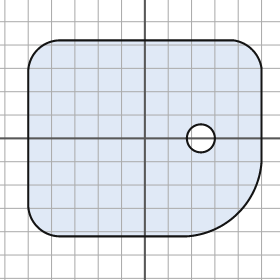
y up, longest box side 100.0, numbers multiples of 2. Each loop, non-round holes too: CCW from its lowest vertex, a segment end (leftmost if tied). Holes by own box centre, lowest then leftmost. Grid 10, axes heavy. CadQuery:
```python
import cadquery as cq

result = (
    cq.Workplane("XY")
    .moveTo(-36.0, -42.0)
    .lineTo(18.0, -42.0)
    .threePointArc((40.0, -32.0), (50.0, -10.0))
    .lineTo(50.0, 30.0)
    .threePointArc((46.0, 38.0), (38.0, 42.0))
    .lineTo(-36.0, 42.0)
    .threePointArc((-46.0, 38.0), (-50.0, 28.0))
    .lineTo(-50.0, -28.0)
    .threePointArc((-46.0, -38.0), (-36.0, -42.0))
    .close()
    .moveTo(24.0, 0.0)
    .circle(6.0)
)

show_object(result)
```